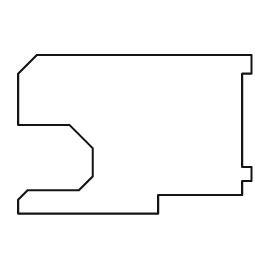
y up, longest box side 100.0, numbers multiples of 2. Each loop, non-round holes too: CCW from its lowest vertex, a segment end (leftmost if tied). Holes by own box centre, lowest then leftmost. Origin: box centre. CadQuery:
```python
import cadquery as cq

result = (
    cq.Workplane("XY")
    .moveTo(-50.0, -34.0)
    .lineTo(10.0, -34.0)
    .lineTo(10.0, -26.0)
    .lineTo(46.0, -26.0)
    .lineTo(46.0, -20.0)
    .lineTo(50.0, -20.0)
    .lineTo(50.0, -14.0)
    .lineTo(46.0, -14.0)
    .lineTo(46.0, 26.0)
    .lineTo(50.0, 26.0)
    .lineTo(50.0, 34.0)
    .lineTo(-42.0, 34.0)
    .lineTo(-50.0, 26.0)
    .lineTo(-50.0, 4.0)
    .lineTo(-28.0, 4.0)
    .lineTo(-18.0, -6.0)
    .lineTo(-18.0, -18.0)
    .lineTo(-24.0, -24.0)
    .lineTo(-46.0, -24.0)
    .lineTo(-50.0, -28.0)
    .close()
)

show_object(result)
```